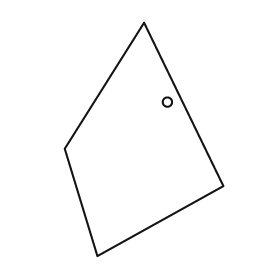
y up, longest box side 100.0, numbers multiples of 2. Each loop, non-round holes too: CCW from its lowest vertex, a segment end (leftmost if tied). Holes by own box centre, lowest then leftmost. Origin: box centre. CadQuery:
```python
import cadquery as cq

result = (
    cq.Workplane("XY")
    .moveTo(-20.0, -50.0)
    .lineTo(34.0, -20.0)
    .lineTo(0.0, 50.0)
    .lineTo(-34.0, -4.0)
    .close()
    .moveTo(10.0, 16.0)
    .circle(2.0)
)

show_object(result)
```